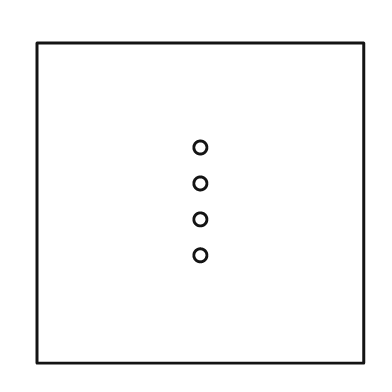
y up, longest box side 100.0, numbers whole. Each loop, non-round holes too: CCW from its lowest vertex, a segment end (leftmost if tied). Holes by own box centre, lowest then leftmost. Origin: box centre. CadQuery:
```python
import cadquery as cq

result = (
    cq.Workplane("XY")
    .moveTo(-50.0, -49.0)
    .lineTo(50.0, -49.0)
    .lineTo(50.0, 49.0)
    .lineTo(-50.0, 49.0)
    .close()
    .moveTo(0.0, -16.0)
    .circle(2.0)
    .moveTo(0.0, -5.0)
    .circle(2.0)
    .moveTo(0.0, 6.0)
    .circle(2.0)
    .moveTo(0.0, 17.0)
    .circle(2.0)
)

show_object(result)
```